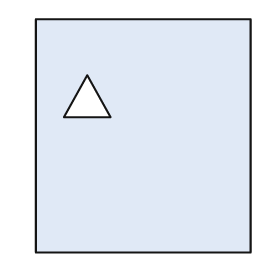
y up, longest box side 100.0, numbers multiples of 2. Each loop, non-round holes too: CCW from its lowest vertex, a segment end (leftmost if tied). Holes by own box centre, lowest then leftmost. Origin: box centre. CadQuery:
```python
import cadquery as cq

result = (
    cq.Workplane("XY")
    .moveTo(-46.0, -50.0)
    .lineTo(46.0, -50.0)
    .lineTo(46.0, 50.0)
    .lineTo(-46.0, 50.0)
    .close()
    .moveTo(-34.0, 8.0)
    .lineTo(-14.0, 8.0)
    .lineTo(-24.0, 26.0)
    .close()
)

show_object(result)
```